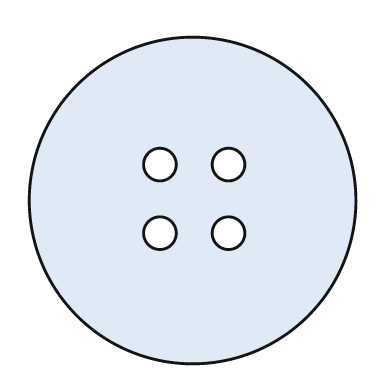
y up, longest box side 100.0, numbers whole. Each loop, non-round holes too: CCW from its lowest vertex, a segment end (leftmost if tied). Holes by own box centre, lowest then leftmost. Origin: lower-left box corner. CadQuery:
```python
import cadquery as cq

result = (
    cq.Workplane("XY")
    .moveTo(50.0, 50.0)
    .circle(50.0)
    .moveTo(40.0, 40.0)
    .circle(5.0)
    .moveTo(61.0, 40.0)
    .circle(5.0)
    .moveTo(40.0, 61.0)
    .circle(5.0)
    .moveTo(61.0, 61.0)
    .circle(5.0)
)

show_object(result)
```